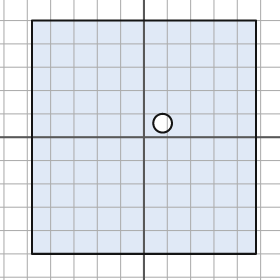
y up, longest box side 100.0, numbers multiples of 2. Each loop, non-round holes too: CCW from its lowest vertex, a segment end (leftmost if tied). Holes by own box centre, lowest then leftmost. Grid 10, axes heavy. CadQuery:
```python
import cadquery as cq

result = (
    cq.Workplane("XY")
    .moveTo(-48.0, -50.0)
    .lineTo(48.0, -50.0)
    .lineTo(48.0, 50.0)
    .lineTo(-48.0, 50.0)
    .close()
    .moveTo(8.0, 6.0)
    .circle(4.0)
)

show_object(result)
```